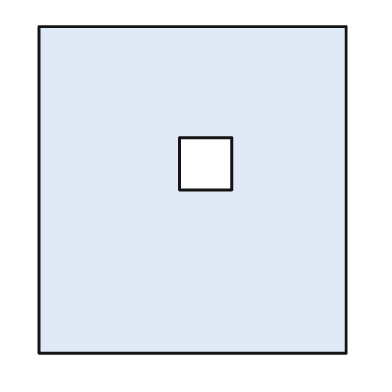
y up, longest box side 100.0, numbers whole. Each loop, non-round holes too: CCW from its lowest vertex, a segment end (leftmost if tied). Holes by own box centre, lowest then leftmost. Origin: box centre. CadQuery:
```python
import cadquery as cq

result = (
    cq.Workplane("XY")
    .moveTo(-47.0, -50.0)
    .lineTo(47.0, -50.0)
    .lineTo(47.0, 50.0)
    .lineTo(-47.0, 50.0)
    .close()
    .moveTo(-4.0, 0.0)
    .lineTo(12.0, 0.0)
    .lineTo(12.0, 16.0)
    .lineTo(-4.0, 16.0)
    .close()
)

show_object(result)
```